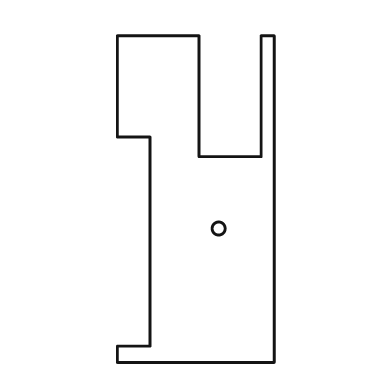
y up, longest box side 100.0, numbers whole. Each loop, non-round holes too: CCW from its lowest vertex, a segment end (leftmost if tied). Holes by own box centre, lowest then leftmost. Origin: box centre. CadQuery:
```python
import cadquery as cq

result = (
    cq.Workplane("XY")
    .moveTo(-24.0, -50.0)
    .lineTo(24.0, -50.0)
    .lineTo(24.0, 50.0)
    .lineTo(20.0, 50.0)
    .lineTo(20.0, 13.0)
    .lineTo(1.0, 13.0)
    .lineTo(1.0, 50.0)
    .lineTo(-24.0, 50.0)
    .lineTo(-24.0, 19.0)
    .lineTo(-14.0, 19.0)
    .lineTo(-14.0, -45.0)
    .lineTo(-24.0, -45.0)
    .close()
    .moveTo(7.0, -9.0)
    .circle(2.0)
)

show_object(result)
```